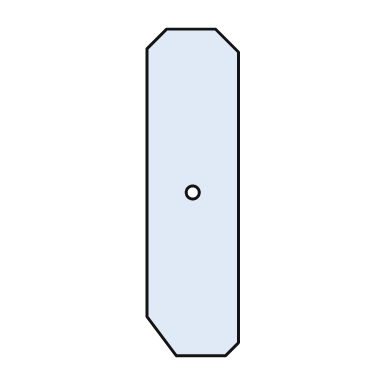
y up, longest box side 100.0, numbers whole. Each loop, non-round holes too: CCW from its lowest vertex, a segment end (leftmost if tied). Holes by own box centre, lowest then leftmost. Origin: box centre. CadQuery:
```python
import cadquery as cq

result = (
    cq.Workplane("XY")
    .moveTo(-5.0, -50.0)
    .lineTo(10.0, -50.0)
    .lineTo(14.0, -46.0)
    .lineTo(14.0, 43.0)
    .lineTo(7.0, 50.0)
    .lineTo(-8.0, 50.0)
    .lineTo(-14.0, 44.0)
    .lineTo(-14.0, -38.0)
    .close()
    .moveTo(0.0, 0.0)
    .circle(2.0)
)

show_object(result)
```